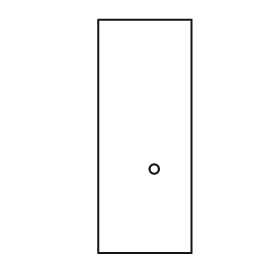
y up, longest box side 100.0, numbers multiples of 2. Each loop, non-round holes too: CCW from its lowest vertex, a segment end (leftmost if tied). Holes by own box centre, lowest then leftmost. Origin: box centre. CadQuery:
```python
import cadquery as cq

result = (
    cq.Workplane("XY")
    .moveTo(-20.0, -50.0)
    .lineTo(20.0, -50.0)
    .lineTo(20.0, 50.0)
    .lineTo(-20.0, 50.0)
    .close()
    .moveTo(4.0, -14.0)
    .circle(2.0)
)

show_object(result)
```